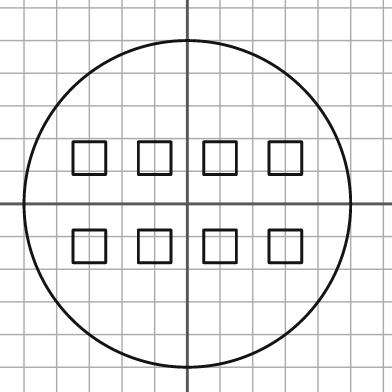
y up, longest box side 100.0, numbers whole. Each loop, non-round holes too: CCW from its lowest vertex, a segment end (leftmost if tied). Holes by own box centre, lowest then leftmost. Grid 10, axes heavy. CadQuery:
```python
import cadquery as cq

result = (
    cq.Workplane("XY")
    .moveTo(0.0, 0.0)
    .circle(50.0)
    .moveTo(-35.0, -18.0)
    .lineTo(-25.0, -18.0)
    .lineTo(-25.0, -8.0)
    .lineTo(-35.0, -8.0)
    .close()
    .moveTo(-15.0, -18.0)
    .lineTo(-5.0, -18.0)
    .lineTo(-5.0, -8.0)
    .lineTo(-15.0, -8.0)
    .close()
    .moveTo(5.0, -18.0)
    .lineTo(15.0, -18.0)
    .lineTo(15.0, -8.0)
    .lineTo(5.0, -8.0)
    .close()
    .moveTo(25.0, -18.0)
    .lineTo(35.0, -18.0)
    .lineTo(35.0, -8.0)
    .lineTo(25.0, -8.0)
    .close()
    .moveTo(-35.0, 9.0)
    .lineTo(-25.0, 9.0)
    .lineTo(-25.0, 19.0)
    .lineTo(-35.0, 19.0)
    .close()
    .moveTo(-15.0, 9.0)
    .lineTo(-5.0, 9.0)
    .lineTo(-5.0, 19.0)
    .lineTo(-15.0, 19.0)
    .close()
    .moveTo(5.0, 9.0)
    .lineTo(15.0, 9.0)
    .lineTo(15.0, 19.0)
    .lineTo(5.0, 19.0)
    .close()
    .moveTo(25.0, 9.0)
    .lineTo(35.0, 9.0)
    .lineTo(35.0, 19.0)
    .lineTo(25.0, 19.0)
    .close()
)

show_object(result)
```